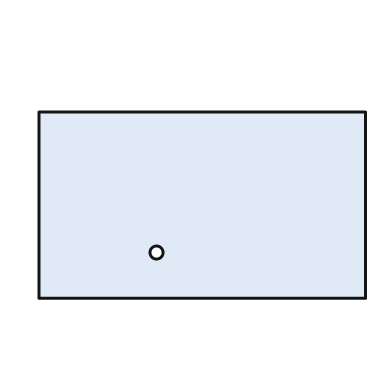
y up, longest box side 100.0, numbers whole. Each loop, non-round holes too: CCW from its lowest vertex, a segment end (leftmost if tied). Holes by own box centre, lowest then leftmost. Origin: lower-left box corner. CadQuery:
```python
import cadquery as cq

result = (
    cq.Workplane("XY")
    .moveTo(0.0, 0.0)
    .lineTo(100.0, 0.0)
    .lineTo(100.0, 57.0)
    .lineTo(0.0, 57.0)
    .close()
    .moveTo(36.0, 14.0)
    .circle(2.0)
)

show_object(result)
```